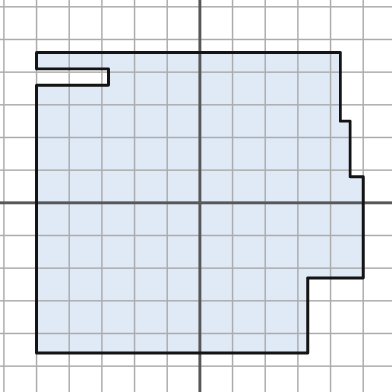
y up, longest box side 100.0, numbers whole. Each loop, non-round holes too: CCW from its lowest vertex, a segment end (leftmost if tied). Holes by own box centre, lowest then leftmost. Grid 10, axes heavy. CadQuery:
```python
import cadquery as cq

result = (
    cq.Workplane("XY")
    .moveTo(-50.0, -46.0)
    .lineTo(33.0, -46.0)
    .lineTo(33.0, -23.0)
    .lineTo(50.0, -23.0)
    .lineTo(50.0, 8.0)
    .lineTo(46.0, 8.0)
    .lineTo(46.0, 25.0)
    .lineTo(43.0, 25.0)
    .lineTo(43.0, 46.0)
    .lineTo(-50.0, 46.0)
    .lineTo(-50.0, 41.0)
    .lineTo(-28.0, 41.0)
    .lineTo(-28.0, 36.0)
    .lineTo(-50.0, 36.0)
    .close()
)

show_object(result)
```